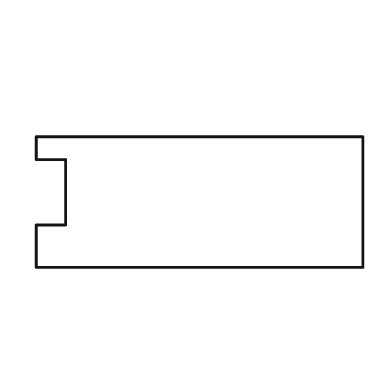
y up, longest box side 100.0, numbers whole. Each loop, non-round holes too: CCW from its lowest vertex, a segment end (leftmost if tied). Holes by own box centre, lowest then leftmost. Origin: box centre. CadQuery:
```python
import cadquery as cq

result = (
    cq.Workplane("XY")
    .moveTo(-50.0, -20.0)
    .lineTo(50.0, -20.0)
    .lineTo(50.0, 20.0)
    .lineTo(-50.0, 20.0)
    .lineTo(-50.0, 13.0)
    .lineTo(-41.0, 13.0)
    .lineTo(-41.0, -7.0)
    .lineTo(-50.0, -7.0)
    .close()
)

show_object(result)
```